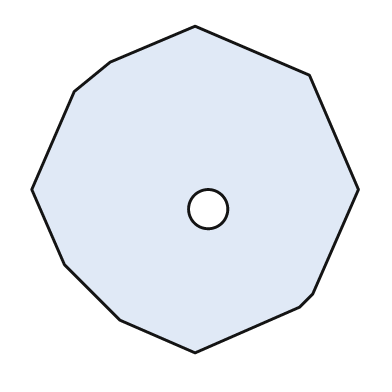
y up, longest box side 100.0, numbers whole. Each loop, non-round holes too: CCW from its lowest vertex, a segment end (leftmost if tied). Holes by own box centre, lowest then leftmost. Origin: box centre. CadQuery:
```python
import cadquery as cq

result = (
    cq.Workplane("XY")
    .moveTo(0.0, -50.0)
    .lineTo(32.0, -36.0)
    .lineTo(36.0, -32.0)
    .lineTo(50.0, 0.0)
    .lineTo(35.0, 35.0)
    .lineTo(0.0, 50.0)
    .lineTo(-26.0, 39.0)
    .lineTo(-37.0, 30.0)
    .lineTo(-50.0, 0.0)
    .lineTo(-40.0, -23.0)
    .lineTo(-23.0, -40.0)
    .close()
    .moveTo(4.0, -6.0)
    .circle(6.0)
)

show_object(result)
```